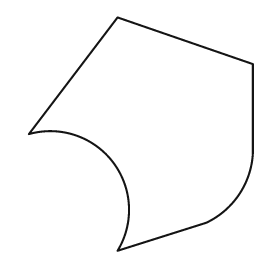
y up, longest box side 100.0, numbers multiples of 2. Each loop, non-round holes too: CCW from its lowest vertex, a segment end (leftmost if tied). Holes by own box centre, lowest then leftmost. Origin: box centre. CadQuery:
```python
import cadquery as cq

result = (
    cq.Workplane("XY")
    .moveTo(-10.0, -50.0)
    .lineTo(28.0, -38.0)
    .threePointArc((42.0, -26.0), (48.0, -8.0))
    .lineTo(48.0, 30.0)
    .lineTo(-10.0, 50.0)
    .lineTo(-48.0, 0.0)
    .threePointArc((-12.0, -12.0), (-10.0, -50.0))
    .close()
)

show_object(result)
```